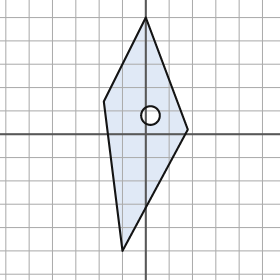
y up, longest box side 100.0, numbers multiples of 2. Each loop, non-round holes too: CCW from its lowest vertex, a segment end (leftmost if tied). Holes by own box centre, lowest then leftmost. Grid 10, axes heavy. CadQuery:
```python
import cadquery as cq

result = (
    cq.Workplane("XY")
    .moveTo(-10.0, -50.0)
    .lineTo(18.0, 2.0)
    .lineTo(0.0, 50.0)
    .lineTo(-18.0, 14.0)
    .close()
    .moveTo(2.0, 8.0)
    .circle(4.0)
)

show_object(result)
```